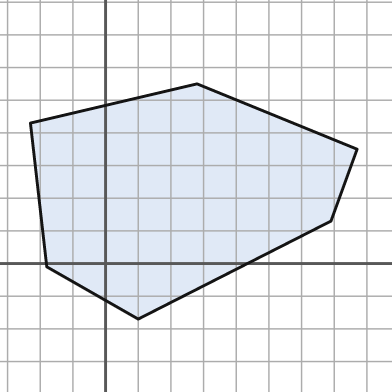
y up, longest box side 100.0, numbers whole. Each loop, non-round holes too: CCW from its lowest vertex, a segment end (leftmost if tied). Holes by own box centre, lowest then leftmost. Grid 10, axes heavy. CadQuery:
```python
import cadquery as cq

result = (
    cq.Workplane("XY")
    .moveTo(10.0, -17.0)
    .lineTo(69.0, 13.0)
    .lineTo(77.0, 35.0)
    .lineTo(28.0, 55.0)
    .lineTo(-23.0, 43.0)
    .lineTo(-18.0, -1.0)
    .close()
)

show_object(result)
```